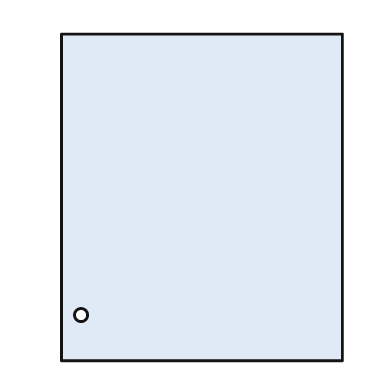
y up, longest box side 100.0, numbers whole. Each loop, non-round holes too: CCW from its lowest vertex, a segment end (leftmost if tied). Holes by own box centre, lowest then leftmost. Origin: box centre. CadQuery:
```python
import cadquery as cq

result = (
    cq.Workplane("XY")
    .moveTo(-43.0, -50.0)
    .lineTo(43.0, -50.0)
    .lineTo(43.0, 50.0)
    .lineTo(-43.0, 50.0)
    .close()
    .moveTo(-37.0, -36.0)
    .circle(2.0)
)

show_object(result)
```